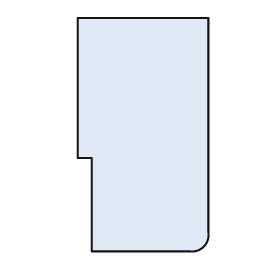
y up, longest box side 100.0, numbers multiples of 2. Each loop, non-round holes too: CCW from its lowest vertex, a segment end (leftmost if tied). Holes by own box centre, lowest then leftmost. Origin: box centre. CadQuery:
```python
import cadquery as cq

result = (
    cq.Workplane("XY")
    .moveTo(-22.0, -50.0)
    .lineTo(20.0, -50.0)
    .threePointArc((26.0, -48.0), (28.0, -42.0))
    .lineTo(28.0, 50.0)
    .lineTo(-28.0, 50.0)
    .lineTo(-28.0, -10.0)
    .lineTo(-22.0, -10.0)
    .close()
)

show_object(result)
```